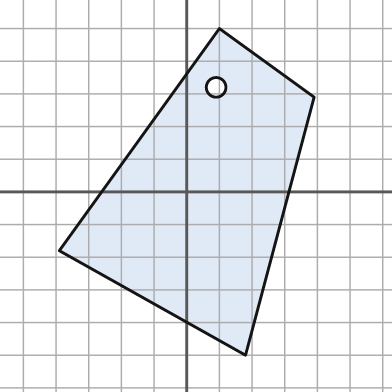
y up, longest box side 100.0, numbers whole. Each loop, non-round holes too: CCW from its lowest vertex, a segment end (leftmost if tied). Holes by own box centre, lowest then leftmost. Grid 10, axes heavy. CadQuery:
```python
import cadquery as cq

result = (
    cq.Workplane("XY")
    .moveTo(18.0, -50.0)
    .lineTo(39.0, 29.0)
    .lineTo(10.0, 50.0)
    .lineTo(-39.0, -18.0)
    .close()
    .moveTo(9.0, 32.0)
    .circle(3.0)
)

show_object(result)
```